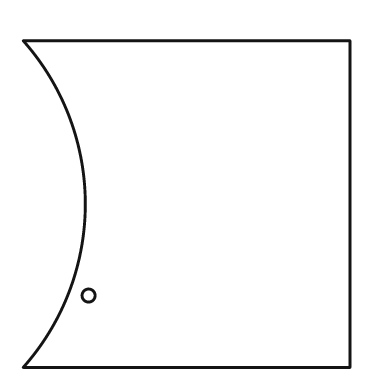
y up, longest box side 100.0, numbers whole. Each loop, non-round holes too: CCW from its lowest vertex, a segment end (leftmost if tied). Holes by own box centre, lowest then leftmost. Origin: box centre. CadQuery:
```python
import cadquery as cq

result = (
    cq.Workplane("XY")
    .moveTo(-50.0, -50.0)
    .lineTo(50.0, -50.0)
    .lineTo(50.0, 50.0)
    .lineTo(-50.0, 50.0)
    .threePointArc((-31.0, 0.0), (-50.0, -50.0))
    .close()
    .moveTo(-30.0, -28.0)
    .circle(2.0)
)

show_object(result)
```